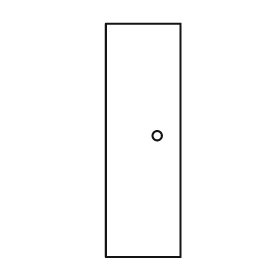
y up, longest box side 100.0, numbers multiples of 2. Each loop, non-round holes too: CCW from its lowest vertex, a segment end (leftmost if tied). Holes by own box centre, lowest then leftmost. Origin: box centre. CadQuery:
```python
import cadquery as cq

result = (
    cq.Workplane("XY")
    .moveTo(-16.0, -50.0)
    .lineTo(16.0, -50.0)
    .lineTo(16.0, 50.0)
    .lineTo(-16.0, 50.0)
    .close()
    .moveTo(6.0, 2.0)
    .circle(2.0)
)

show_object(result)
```